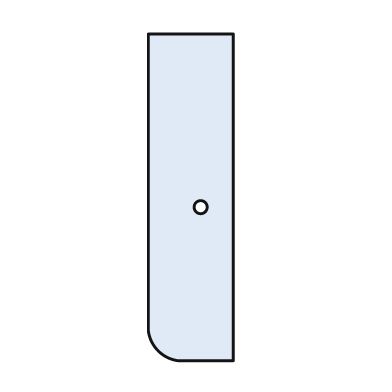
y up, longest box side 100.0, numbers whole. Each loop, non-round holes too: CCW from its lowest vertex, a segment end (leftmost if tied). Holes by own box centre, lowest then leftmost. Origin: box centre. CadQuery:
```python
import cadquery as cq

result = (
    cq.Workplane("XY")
    .moveTo(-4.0, -50.0)
    .lineTo(13.0, -50.0)
    .lineTo(13.0, 50.0)
    .lineTo(-13.0, 50.0)
    .lineTo(-13.0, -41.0)
    .threePointArc((-10.0, -47.0), (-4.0, -50.0))
    .close()
    .moveTo(3.0, -3.0)
    .circle(2.0)
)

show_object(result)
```